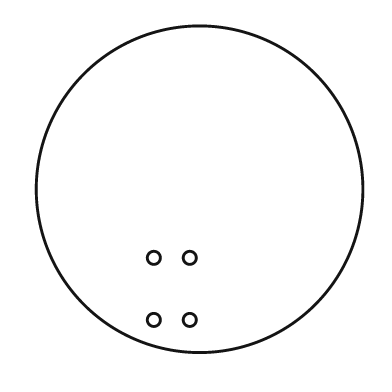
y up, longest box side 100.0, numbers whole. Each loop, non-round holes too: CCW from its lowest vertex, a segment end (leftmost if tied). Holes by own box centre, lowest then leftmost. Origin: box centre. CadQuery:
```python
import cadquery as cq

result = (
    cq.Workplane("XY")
    .moveTo(0.0, 0.0)
    .circle(50.0)
    .moveTo(-14.0, -40.0)
    .circle(2.0)
    .moveTo(-3.0, -40.0)
    .circle(2.0)
    .moveTo(-14.0, -21.0)
    .circle(2.0)
    .moveTo(-3.0, -21.0)
    .circle(2.0)
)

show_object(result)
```